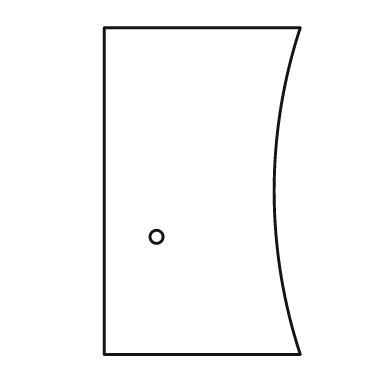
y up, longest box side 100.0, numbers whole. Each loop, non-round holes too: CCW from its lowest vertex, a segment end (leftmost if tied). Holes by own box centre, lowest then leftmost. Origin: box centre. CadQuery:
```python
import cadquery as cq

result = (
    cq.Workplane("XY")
    .moveTo(-30.0, -50.0)
    .lineTo(30.0, -50.0)
    .threePointArc((22.0, 0.0), (30.0, 50.0))
    .lineTo(-30.0, 50.0)
    .close()
    .moveTo(-14.0, -14.0)
    .circle(2.0)
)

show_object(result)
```